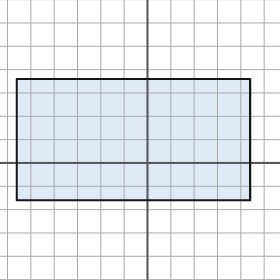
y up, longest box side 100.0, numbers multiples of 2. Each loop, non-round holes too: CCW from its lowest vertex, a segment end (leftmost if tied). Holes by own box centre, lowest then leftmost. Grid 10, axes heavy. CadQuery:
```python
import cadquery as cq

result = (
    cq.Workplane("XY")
    .moveTo(-56.0, -16.0)
    .lineTo(44.0, -16.0)
    .lineTo(44.0, 36.0)
    .lineTo(-56.0, 36.0)
    .close()
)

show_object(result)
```